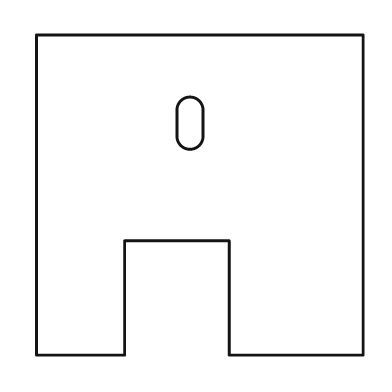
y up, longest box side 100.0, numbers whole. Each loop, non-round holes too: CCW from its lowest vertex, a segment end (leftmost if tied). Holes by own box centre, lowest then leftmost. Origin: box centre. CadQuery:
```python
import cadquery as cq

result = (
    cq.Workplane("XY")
    .moveTo(-50.0, -49.0)
    .lineTo(-23.0, -49.0)
    .lineTo(-23.0, -14.0)
    .lineTo(9.0, -14.0)
    .lineTo(9.0, -49.0)
    .lineTo(50.0, -49.0)
    .lineTo(50.0, 49.0)
    .lineTo(-50.0, 49.0)
    .close()
    .moveTo(-7.0, 18.0)
    .threePointArc((-3.0, 14.0), (1.0, 18.0))
    .lineTo(1.0, 26.0)
    .threePointArc((-3.0, 30.0), (-7.0, 26.0))
    .close()
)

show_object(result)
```